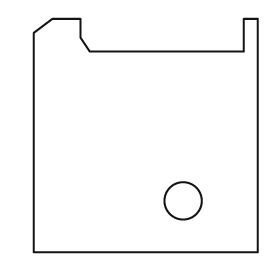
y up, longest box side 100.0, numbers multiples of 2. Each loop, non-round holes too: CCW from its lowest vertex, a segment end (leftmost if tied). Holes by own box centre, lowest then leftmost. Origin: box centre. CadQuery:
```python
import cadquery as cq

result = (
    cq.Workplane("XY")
    .moveTo(-48.0, -50.0)
    .lineTo(48.0, -50.0)
    .lineTo(48.0, 50.0)
    .lineTo(42.0, 50.0)
    .lineTo(42.0, 36.0)
    .lineTo(-24.0, 36.0)
    .lineTo(-28.0, 42.0)
    .lineTo(-28.0, 50.0)
    .lineTo(-40.0, 50.0)
    .lineTo(-48.0, 44.0)
    .close()
    .moveTo(16.0, -28.0)
    .circle(8.0)
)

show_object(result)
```